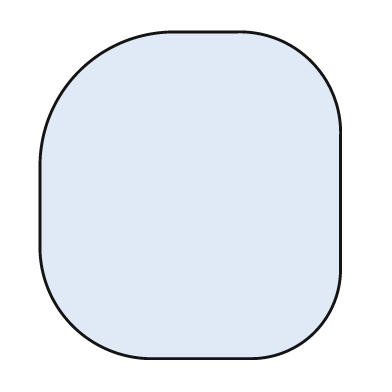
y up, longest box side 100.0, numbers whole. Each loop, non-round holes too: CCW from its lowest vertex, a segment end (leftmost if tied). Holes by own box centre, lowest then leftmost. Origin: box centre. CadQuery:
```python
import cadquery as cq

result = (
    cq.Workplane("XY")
    .moveTo(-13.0, -50.0)
    .lineTo(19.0, -50.0)
    .threePointArc((38.0, -42.0), (46.0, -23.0))
    .lineTo(46.0, 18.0)
    .threePointArc((37.0, 41.0), (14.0, 50.0))
    .lineTo(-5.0, 50.0)
    .threePointArc((-34.0, 38.0), (-46.0, 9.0))
    .lineTo(-46.0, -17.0)
    .threePointArc((-36.0, -40.0), (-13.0, -50.0))
    .close()
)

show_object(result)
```